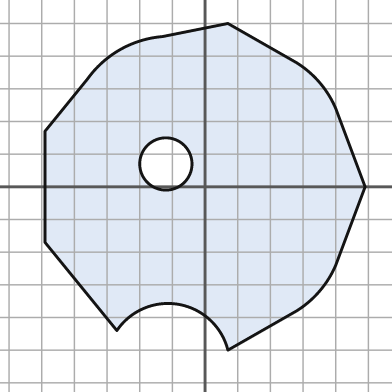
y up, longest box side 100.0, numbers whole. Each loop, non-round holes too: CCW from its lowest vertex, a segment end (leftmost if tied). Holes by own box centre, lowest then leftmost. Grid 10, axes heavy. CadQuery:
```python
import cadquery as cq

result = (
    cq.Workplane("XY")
    .moveTo(7.0, -50.0)
    .lineTo(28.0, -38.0)
    .threePointArc((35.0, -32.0), (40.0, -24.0))
    .lineTo(49.0, 0.0)
    .lineTo(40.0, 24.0)
    .threePointArc((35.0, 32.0), (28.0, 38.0))
    .lineTo(7.0, 50.0)
    .lineTo(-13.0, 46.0)
    .threePointArc((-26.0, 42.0), (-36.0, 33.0))
    .lineTo(-49.0, 17.0)
    .lineTo(-49.0, -17.0)
    .lineTo(-27.0, -44.0)
    .threePointArc((-8.0, -36.0), (7.0, -50.0))
    .close()
    .moveTo(-12.0, 7.0)
    .circle(8.0)
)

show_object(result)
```